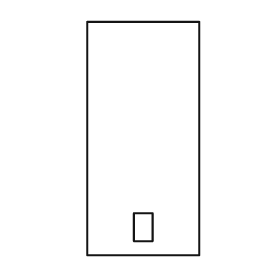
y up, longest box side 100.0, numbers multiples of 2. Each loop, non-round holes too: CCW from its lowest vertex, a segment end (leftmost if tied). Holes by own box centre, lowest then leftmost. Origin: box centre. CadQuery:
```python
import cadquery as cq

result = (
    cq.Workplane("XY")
    .moveTo(-24.0, -50.0)
    .lineTo(24.0, -50.0)
    .lineTo(24.0, 50.0)
    .lineTo(-24.0, 50.0)
    .close()
    .moveTo(-4.0, -44.0)
    .lineTo(4.0, -44.0)
    .lineTo(4.0, -32.0)
    .lineTo(-4.0, -32.0)
    .close()
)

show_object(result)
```